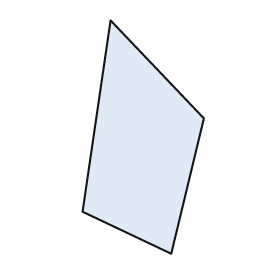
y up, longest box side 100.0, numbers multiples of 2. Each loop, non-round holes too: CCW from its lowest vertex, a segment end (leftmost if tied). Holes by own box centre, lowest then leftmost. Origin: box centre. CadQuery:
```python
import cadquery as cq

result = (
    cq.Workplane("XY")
    .moveTo(12.0, -50.0)
    .lineTo(26.0, 8.0)
    .lineTo(-14.0, 50.0)
    .lineTo(-26.0, -32.0)
    .close()
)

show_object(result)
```